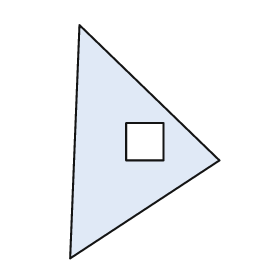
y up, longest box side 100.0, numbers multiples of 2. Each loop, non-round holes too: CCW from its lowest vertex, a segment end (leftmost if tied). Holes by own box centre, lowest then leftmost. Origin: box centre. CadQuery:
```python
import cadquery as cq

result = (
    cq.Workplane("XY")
    .moveTo(-32.0, -50.0)
    .lineTo(32.0, -8.0)
    .lineTo(-28.0, 50.0)
    .close()
    .moveTo(-8.0, -8.0)
    .lineTo(8.0, -8.0)
    .lineTo(8.0, 8.0)
    .lineTo(-8.0, 8.0)
    .close()
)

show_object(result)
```